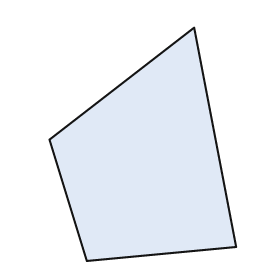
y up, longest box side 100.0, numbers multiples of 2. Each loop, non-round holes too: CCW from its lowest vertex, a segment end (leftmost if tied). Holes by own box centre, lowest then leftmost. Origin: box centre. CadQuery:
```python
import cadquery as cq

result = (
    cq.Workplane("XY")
    .moveTo(-24.0, -50.0)
    .lineTo(40.0, -44.0)
    .lineTo(22.0, 50.0)
    .lineTo(-40.0, 2.0)
    .close()
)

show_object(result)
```